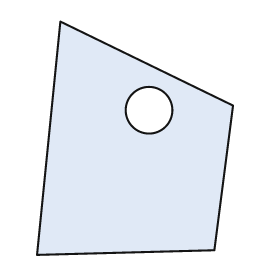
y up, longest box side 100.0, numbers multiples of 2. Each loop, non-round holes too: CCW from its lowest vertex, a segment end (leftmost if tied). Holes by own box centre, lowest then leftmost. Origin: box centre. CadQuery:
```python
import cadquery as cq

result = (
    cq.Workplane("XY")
    .moveTo(-42.0, -50.0)
    .lineTo(34.0, -48.0)
    .lineTo(42.0, 14.0)
    .lineTo(-32.0, 50.0)
    .close()
    .moveTo(6.0, 12.0)
    .circle(10.0)
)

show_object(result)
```